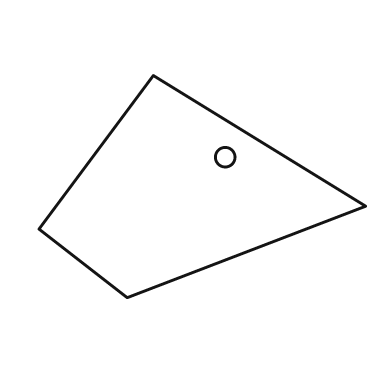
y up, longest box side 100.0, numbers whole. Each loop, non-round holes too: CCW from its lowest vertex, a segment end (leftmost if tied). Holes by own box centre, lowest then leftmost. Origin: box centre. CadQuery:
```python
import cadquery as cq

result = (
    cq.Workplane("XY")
    .moveTo(-23.0, -34.0)
    .lineTo(50.0, -6.0)
    .lineTo(-15.0, 34.0)
    .lineTo(-50.0, -13.0)
    .close()
    .moveTo(7.0, 9.0)
    .circle(3.0)
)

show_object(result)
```